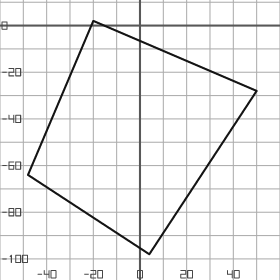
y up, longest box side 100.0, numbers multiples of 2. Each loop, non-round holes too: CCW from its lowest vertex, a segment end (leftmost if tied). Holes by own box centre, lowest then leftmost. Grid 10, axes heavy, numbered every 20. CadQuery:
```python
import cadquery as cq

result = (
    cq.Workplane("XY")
    .moveTo(4.0, -98.0)
    .lineTo(50.0, -28.0)
    .lineTo(-20.0, 2.0)
    .lineTo(-48.0, -64.0)
    .close()
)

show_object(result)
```